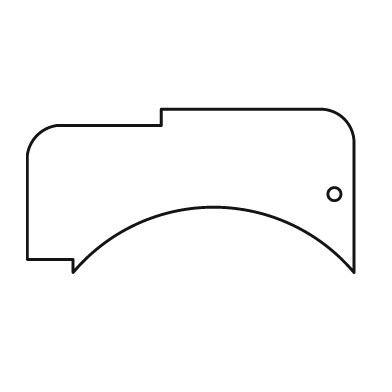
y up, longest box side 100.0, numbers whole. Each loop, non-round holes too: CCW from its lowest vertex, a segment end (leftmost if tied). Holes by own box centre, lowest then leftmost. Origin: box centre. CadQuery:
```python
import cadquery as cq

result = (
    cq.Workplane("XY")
    .moveTo(-36.0, -25.0)
    .threePointArc((7.0, -5.0), (50.0, -25.0))
    .lineTo(50.0, 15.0)
    .threePointArc((47.0, 22.0), (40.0, 25.0))
    .lineTo(-9.0, 25.0)
    .lineTo(-9.0, 20.0)
    .lineTo(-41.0, 20.0)
    .threePointArc((-47.0, 17.0), (-50.0, 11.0))
    .lineTo(-50.0, -21.0)
    .lineTo(-36.0, -21.0)
    .close()
    .moveTo(44.0, -1.0)
    .circle(2.0)
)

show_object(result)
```